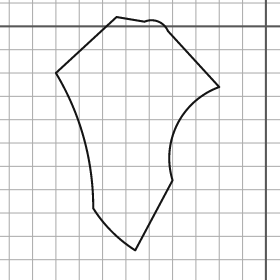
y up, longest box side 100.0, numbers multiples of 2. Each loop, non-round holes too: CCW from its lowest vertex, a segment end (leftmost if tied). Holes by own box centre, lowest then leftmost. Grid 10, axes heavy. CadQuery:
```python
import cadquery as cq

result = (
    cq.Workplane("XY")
    .moveTo(-56.0, -96.0)
    .lineTo(-40.0, -66.0)
    .threePointArc((-38.0, -42.0), (-20.0, -26.0))
    .lineTo(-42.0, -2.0)
    .threePointArc((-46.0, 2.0), (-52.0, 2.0))
    .lineTo(-64.0, 4.0)
    .lineTo(-90.0, -20.0)
    .threePointArc((-78.0, -48.0), (-74.0, -78.0))
    .threePointArc((-66.0, -88.0), (-56.0, -96.0))
    .close()
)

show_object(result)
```